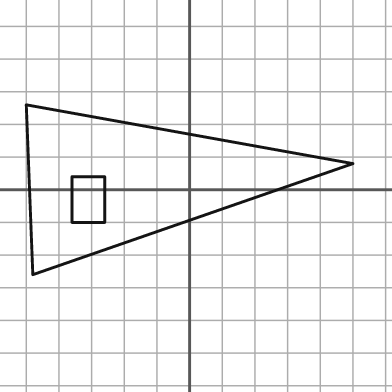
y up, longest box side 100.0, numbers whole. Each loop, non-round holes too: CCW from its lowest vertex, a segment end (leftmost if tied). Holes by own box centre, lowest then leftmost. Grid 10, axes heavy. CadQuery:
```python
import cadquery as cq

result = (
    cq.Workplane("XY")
    .moveTo(-48.0, -26.0)
    .lineTo(50.0, 8.0)
    .lineTo(-50.0, 26.0)
    .close()
    .moveTo(-36.0, -10.0)
    .lineTo(-26.0, -10.0)
    .lineTo(-26.0, 4.0)
    .lineTo(-36.0, 4.0)
    .close()
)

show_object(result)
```